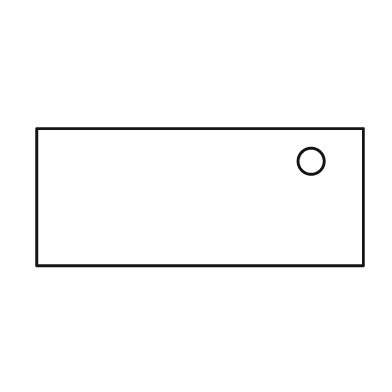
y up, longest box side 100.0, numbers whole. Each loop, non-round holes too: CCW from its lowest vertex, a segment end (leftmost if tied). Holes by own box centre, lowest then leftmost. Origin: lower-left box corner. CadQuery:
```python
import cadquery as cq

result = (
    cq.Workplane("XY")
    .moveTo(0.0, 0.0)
    .lineTo(100.0, 0.0)
    .lineTo(100.0, 42.0)
    .lineTo(0.0, 42.0)
    .close()
    .moveTo(84.0, 32.0)
    .circle(4.0)
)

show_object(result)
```